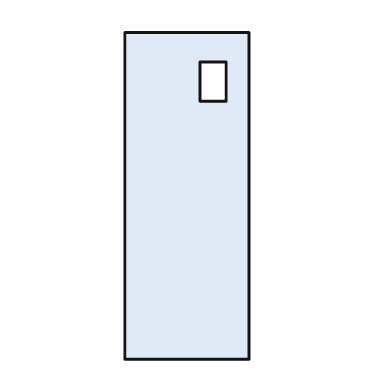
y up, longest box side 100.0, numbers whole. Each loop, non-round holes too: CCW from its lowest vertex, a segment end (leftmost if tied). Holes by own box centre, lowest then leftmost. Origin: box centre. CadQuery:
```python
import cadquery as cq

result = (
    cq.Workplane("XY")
    .moveTo(-19.0, -50.0)
    .lineTo(19.0, -50.0)
    .lineTo(19.0, 50.0)
    .lineTo(-19.0, 50.0)
    .close()
    .moveTo(4.0, 29.0)
    .lineTo(12.0, 29.0)
    .lineTo(12.0, 41.0)
    .lineTo(4.0, 41.0)
    .close()
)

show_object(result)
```